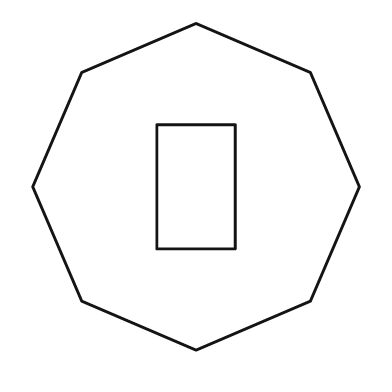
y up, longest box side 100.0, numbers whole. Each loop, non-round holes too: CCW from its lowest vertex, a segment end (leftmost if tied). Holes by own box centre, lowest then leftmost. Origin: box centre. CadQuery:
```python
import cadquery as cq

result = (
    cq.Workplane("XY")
    .moveTo(0.0, -50.0)
    .lineTo(35.0, -35.0)
    .lineTo(50.0, 0.0)
    .lineTo(35.0, 35.0)
    .lineTo(0.0, 50.0)
    .lineTo(-35.0, 35.0)
    .lineTo(-50.0, 0.0)
    .lineTo(-35.0, -35.0)
    .close()
    .moveTo(-12.0, -19.0)
    .lineTo(12.0, -19.0)
    .lineTo(12.0, 19.0)
    .lineTo(-12.0, 19.0)
    .close()
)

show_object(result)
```